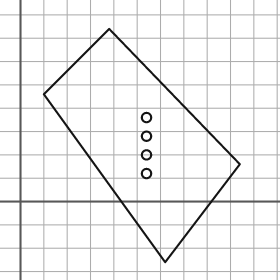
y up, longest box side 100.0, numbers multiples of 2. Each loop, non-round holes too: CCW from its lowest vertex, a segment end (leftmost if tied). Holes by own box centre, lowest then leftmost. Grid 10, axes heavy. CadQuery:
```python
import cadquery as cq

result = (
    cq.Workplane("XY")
    .moveTo(62.0, -26.0)
    .lineTo(94.0, 16.0)
    .lineTo(38.0, 74.0)
    .lineTo(10.0, 46.0)
    .close()
    .moveTo(54.0, 12.0)
    .circle(2.0)
    .moveTo(54.0, 20.0)
    .circle(2.0)
    .moveTo(54.0, 28.0)
    .circle(2.0)
    .moveTo(54.0, 36.0)
    .circle(2.0)
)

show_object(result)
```